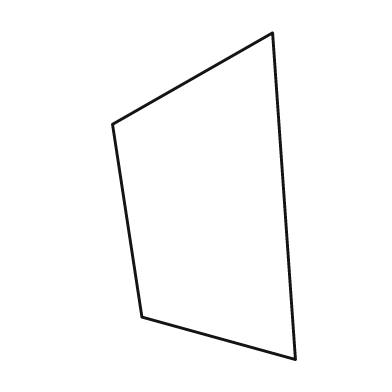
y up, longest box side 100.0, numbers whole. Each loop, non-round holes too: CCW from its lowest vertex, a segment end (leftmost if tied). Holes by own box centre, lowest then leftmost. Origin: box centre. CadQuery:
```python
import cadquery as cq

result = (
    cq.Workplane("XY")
    .moveTo(28.0, -50.0)
    .lineTo(21.0, 50.0)
    .lineTo(-28.0, 22.0)
    .lineTo(-19.0, -37.0)
    .close()
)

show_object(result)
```